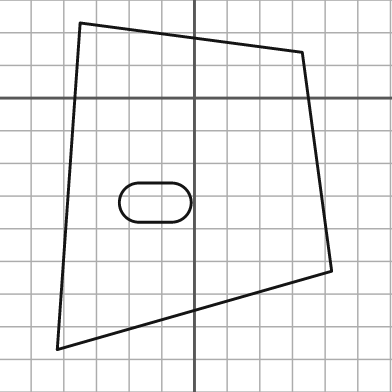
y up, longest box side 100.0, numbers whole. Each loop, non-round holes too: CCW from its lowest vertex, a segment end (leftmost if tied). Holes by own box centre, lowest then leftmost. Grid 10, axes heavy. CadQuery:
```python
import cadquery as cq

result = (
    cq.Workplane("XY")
    .moveTo(-42.0, -77.0)
    .lineTo(42.0, -53.0)
    .lineTo(33.0, 14.0)
    .lineTo(-35.0, 23.0)
    .close()
    .moveTo(-17.0, -38.0)
    .lineTo(-7.0, -38.0)
    .threePointArc((-1.0, -32.0), (-7.0, -26.0))
    .lineTo(-17.0, -26.0)
    .threePointArc((-23.0, -32.0), (-17.0, -38.0))
    .close()
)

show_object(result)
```